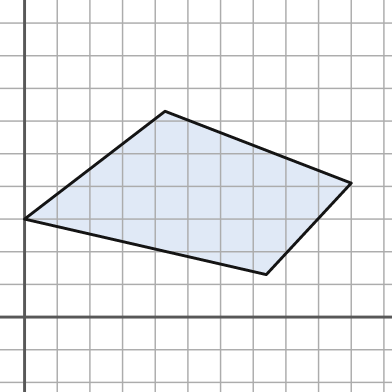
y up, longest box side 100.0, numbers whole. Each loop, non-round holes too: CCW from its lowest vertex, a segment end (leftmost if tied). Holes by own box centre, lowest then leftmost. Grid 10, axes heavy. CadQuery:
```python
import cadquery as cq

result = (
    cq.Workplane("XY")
    .moveTo(74.0, 13.0)
    .lineTo(100.0, 41.0)
    .lineTo(43.0, 63.0)
    .lineTo(0.0, 30.0)
    .close()
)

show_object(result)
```